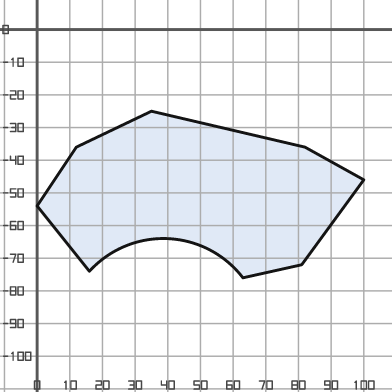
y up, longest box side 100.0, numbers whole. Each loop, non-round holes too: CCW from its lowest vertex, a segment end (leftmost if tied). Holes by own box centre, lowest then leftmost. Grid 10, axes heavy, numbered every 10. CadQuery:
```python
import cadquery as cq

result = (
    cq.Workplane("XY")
    .moveTo(63.0, -76.0)
    .lineTo(81.0, -72.0)
    .lineTo(100.0, -46.0)
    .lineTo(82.0, -36.0)
    .lineTo(35.0, -25.0)
    .lineTo(12.0, -36.0)
    .lineTo(0.0, -54.0)
    .lineTo(16.0, -74.0)
    .threePointArc((40.0, -64.0), (63.0, -76.0))
    .close()
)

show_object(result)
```